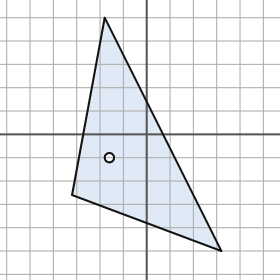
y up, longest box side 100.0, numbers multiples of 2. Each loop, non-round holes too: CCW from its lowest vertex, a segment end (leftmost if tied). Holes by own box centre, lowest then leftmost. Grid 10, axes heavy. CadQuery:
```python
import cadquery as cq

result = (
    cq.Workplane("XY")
    .moveTo(32.0, -50.0)
    .lineTo(-18.0, 50.0)
    .lineTo(-32.0, -26.0)
    .close()
    .moveTo(-16.0, -10.0)
    .circle(2.0)
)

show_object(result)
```